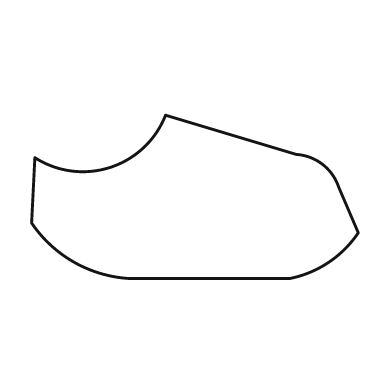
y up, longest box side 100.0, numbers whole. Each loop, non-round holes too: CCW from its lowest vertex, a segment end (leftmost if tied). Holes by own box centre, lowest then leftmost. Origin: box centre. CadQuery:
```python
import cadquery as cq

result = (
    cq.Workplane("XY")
    .moveTo(-20.0, -25.0)
    .lineTo(29.0, -25.0)
    .threePointArc((41.0, -20.0), (50.0, -11.0))
    .lineTo(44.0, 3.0)
    .threePointArc((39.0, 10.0), (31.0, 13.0))
    .lineTo(-9.0, 25.0)
    .threePointArc((-26.0, 9.0), (-49.0, 12.0))
    .lineTo(-50.0, -8.0)
    .threePointArc((-37.0, -20.0), (-20.0, -25.0))
    .close()
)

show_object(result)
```